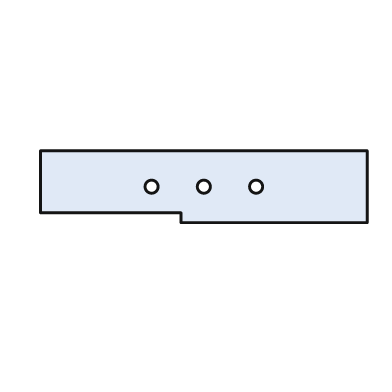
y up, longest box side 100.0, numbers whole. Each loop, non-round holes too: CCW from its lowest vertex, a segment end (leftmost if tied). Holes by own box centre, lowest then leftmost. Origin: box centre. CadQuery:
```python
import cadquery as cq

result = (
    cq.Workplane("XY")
    .moveTo(-7.0, -11.0)
    .lineTo(50.0, -11.0)
    .lineTo(50.0, 11.0)
    .lineTo(-50.0, 11.0)
    .lineTo(-50.0, -8.0)
    .lineTo(-7.0, -8.0)
    .close()
    .moveTo(-16.0, 0.0)
    .circle(2.0)
    .moveTo(0.0, 0.0)
    .circle(2.0)
    .moveTo(16.0, 0.0)
    .circle(2.0)
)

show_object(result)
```